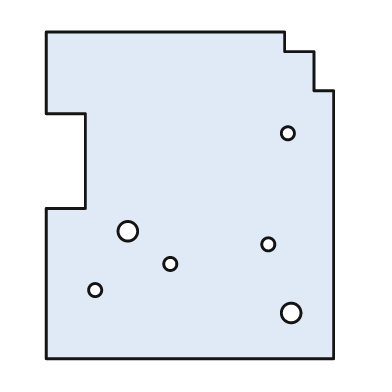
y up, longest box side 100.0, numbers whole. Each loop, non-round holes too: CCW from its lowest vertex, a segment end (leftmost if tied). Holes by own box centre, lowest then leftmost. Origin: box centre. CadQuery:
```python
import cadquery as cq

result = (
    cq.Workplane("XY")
    .moveTo(-44.0, -50.0)
    .lineTo(44.0, -50.0)
    .lineTo(44.0, 32.0)
    .lineTo(38.0, 32.0)
    .lineTo(38.0, 44.0)
    .lineTo(29.0, 44.0)
    .lineTo(29.0, 50.0)
    .lineTo(-44.0, 50.0)
    .lineTo(-44.0, 25.0)
    .lineTo(-32.0, 25.0)
    .lineTo(-32.0, -4.0)
    .lineTo(-44.0, -4.0)
    .close()
    .moveTo(31.0, -36.0)
    .circle(3.0)
    .moveTo(-29.0, -29.0)
    .circle(2.0)
    .moveTo(-6.0, -21.0)
    .circle(2.0)
    .moveTo(24.0, -15.0)
    .circle(2.0)
    .moveTo(-19.0, -11.0)
    .circle(3.0)
    .moveTo(30.0, 19.0)
    .circle(2.0)
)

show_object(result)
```